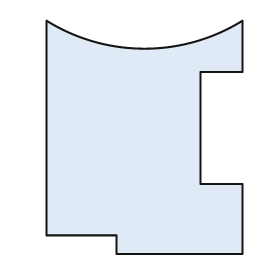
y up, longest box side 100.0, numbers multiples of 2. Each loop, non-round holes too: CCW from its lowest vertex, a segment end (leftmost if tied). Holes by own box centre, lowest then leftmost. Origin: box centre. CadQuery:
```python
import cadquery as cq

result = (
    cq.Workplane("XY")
    .moveTo(-12.0, -50.0)
    .lineTo(42.0, -50.0)
    .lineTo(42.0, -20.0)
    .lineTo(24.0, -20.0)
    .lineTo(24.0, 28.0)
    .lineTo(42.0, 28.0)
    .lineTo(42.0, 50.0)
    .threePointArc((0.0, 38.0), (-42.0, 50.0))
    .lineTo(-42.0, -42.0)
    .lineTo(-12.0, -42.0)
    .close()
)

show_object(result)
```